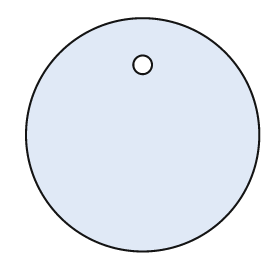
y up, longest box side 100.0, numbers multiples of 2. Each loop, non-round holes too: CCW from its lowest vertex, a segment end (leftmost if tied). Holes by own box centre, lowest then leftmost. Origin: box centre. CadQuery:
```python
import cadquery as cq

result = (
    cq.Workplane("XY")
    .moveTo(0.0, 0.0)
    .circle(50.0)
    .moveTo(0.0, 30.0)
    .circle(4.0)
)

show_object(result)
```